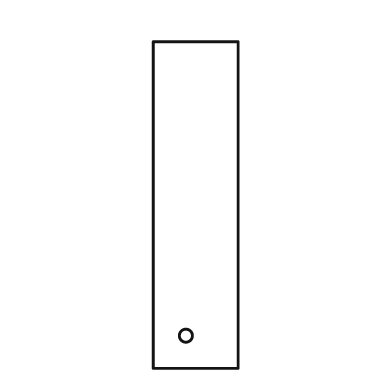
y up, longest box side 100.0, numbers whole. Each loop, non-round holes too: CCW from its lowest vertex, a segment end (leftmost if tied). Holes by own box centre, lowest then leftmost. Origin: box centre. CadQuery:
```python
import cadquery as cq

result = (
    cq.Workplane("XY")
    .moveTo(-13.0, -50.0)
    .lineTo(13.0, -50.0)
    .lineTo(13.0, 50.0)
    .lineTo(-13.0, 50.0)
    .close()
    .moveTo(-3.0, -40.0)
    .circle(2.0)
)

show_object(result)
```